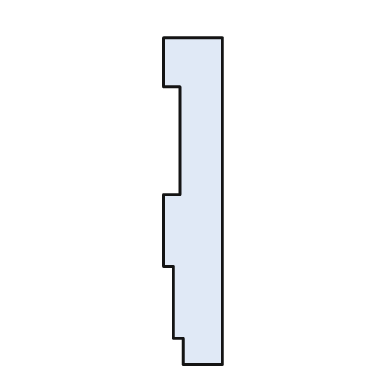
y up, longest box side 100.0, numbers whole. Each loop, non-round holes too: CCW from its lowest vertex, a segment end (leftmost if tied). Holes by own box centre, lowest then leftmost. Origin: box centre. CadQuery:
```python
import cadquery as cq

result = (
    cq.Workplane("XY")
    .moveTo(-3.0, -50.0)
    .lineTo(9.0, -50.0)
    .lineTo(9.0, 50.0)
    .lineTo(-9.0, 50.0)
    .lineTo(-9.0, 35.0)
    .lineTo(-4.0, 35.0)
    .lineTo(-4.0, 2.0)
    .lineTo(-9.0, 2.0)
    .lineTo(-9.0, -20.0)
    .lineTo(-6.0, -20.0)
    .lineTo(-6.0, -42.0)
    .lineTo(-3.0, -42.0)
    .close()
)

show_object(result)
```